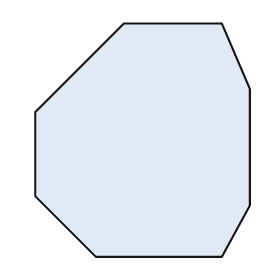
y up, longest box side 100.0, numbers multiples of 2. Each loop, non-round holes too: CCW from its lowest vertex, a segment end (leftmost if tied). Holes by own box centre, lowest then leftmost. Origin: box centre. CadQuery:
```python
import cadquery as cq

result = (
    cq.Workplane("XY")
    .moveTo(-20.0, -50.0)
    .lineTo(34.0, -50.0)
    .lineTo(46.0, -28.0)
    .lineTo(46.0, 22.0)
    .lineTo(34.0, 50.0)
    .lineTo(-8.0, 50.0)
    .lineTo(-46.0, 12.0)
    .lineTo(-46.0, -24.0)
    .close()
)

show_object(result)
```